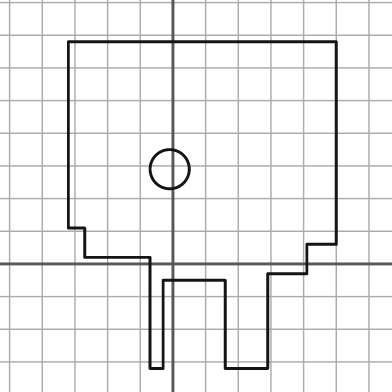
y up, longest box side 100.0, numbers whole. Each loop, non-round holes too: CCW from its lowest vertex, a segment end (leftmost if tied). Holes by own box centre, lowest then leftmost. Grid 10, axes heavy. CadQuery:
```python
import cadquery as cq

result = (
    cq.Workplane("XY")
    .moveTo(-7.0, -32.0)
    .lineTo(-3.0, -32.0)
    .lineTo(-3.0, -5.0)
    .lineTo(16.0, -5.0)
    .lineTo(16.0, -32.0)
    .lineTo(29.0, -32.0)
    .lineTo(29.0, -3.0)
    .lineTo(41.0, -3.0)
    .lineTo(41.0, 6.0)
    .lineTo(50.0, 6.0)
    .lineTo(50.0, 68.0)
    .lineTo(-32.0, 68.0)
    .lineTo(-32.0, 11.0)
    .lineTo(-27.0, 11.0)
    .lineTo(-27.0, 2.0)
    .lineTo(-7.0, 2.0)
    .close()
    .moveTo(-1.0, 29.0)
    .circle(6.0)
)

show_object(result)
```